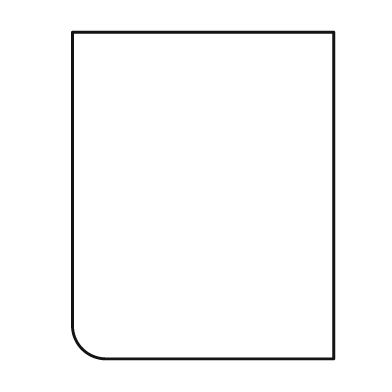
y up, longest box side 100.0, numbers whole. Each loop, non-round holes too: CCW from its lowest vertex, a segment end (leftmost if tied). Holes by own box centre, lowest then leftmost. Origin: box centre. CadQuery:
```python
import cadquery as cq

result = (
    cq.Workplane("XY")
    .moveTo(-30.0, -50.0)
    .lineTo(40.0, -50.0)
    .lineTo(40.0, 50.0)
    .lineTo(-40.0, 50.0)
    .lineTo(-40.0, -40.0)
    .threePointArc((-37.0, -47.0), (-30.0, -50.0))
    .close()
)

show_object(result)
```